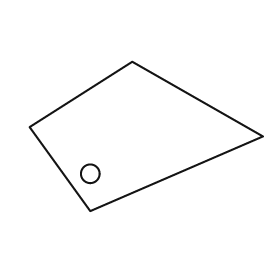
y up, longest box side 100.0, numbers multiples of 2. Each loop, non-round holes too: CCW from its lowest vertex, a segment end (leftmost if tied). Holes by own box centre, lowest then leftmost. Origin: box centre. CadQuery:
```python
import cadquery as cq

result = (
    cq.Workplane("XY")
    .moveTo(-24.0, -32.0)
    .lineTo(50.0, 0.0)
    .lineTo(-6.0, 32.0)
    .lineTo(-50.0, 4.0)
    .close()
    .moveTo(-24.0, -16.0)
    .circle(4.0)
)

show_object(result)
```